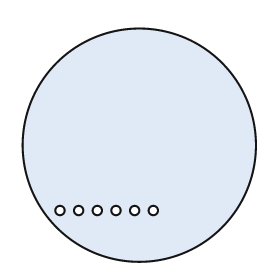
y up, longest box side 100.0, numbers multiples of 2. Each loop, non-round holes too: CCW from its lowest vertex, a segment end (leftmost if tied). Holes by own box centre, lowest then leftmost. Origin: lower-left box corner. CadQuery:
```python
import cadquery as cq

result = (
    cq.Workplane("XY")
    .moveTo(50.0, 50.0)
    .circle(50.0)
    .moveTo(16.0, 22.0)
    .circle(2.0)
    .moveTo(24.0, 22.0)
    .circle(2.0)
    .moveTo(32.0, 22.0)
    .circle(2.0)
    .moveTo(40.0, 22.0)
    .circle(2.0)
    .moveTo(48.0, 22.0)
    .circle(2.0)
    .moveTo(56.0, 22.0)
    .circle(2.0)
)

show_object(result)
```